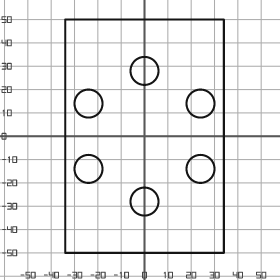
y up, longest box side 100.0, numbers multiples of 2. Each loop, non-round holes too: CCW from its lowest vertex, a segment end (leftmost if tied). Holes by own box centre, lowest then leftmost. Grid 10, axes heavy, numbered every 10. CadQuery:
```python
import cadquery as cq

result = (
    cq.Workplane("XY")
    .moveTo(-34.0, -50.0)
    .lineTo(34.0, -50.0)
    .lineTo(34.0, 50.0)
    .lineTo(-34.0, 50.0)
    .close()
    .moveTo(0.0, -28.0)
    .circle(6.0)
    .moveTo(-24.0, -14.0)
    .circle(6.0)
    .moveTo(24.0, -14.0)
    .circle(6.0)
    .moveTo(-24.0, 14.0)
    .circle(6.0)
    .moveTo(24.0, 14.0)
    .circle(6.0)
    .moveTo(0.0, 28.0)
    .circle(6.0)
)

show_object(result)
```